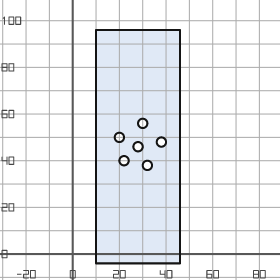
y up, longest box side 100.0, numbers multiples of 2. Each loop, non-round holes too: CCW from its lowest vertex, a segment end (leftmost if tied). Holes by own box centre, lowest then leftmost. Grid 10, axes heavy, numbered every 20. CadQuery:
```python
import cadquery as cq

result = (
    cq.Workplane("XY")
    .moveTo(10.0, -4.0)
    .lineTo(46.0, -4.0)
    .lineTo(46.0, 96.0)
    .lineTo(10.0, 96.0)
    .close()
    .moveTo(32.0, 38.0)
    .circle(2.0)
    .moveTo(22.0, 40.0)
    .circle(2.0)
    .moveTo(28.0, 46.0)
    .circle(2.0)
    .moveTo(38.0, 48.0)
    .circle(2.0)
    .moveTo(20.0, 50.0)
    .circle(2.0)
    .moveTo(30.0, 56.0)
    .circle(2.0)
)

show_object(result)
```